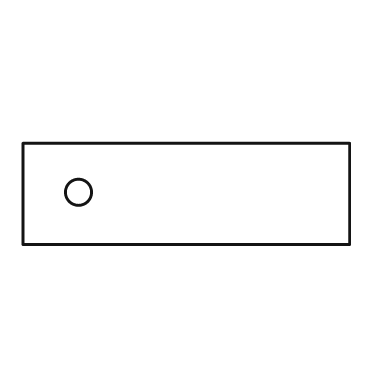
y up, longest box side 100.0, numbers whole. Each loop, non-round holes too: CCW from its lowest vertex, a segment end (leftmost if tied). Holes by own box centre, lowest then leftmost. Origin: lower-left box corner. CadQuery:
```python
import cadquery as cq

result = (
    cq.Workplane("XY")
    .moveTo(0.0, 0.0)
    .lineTo(100.0, 0.0)
    .lineTo(100.0, 31.0)
    .lineTo(0.0, 31.0)
    .close()
    .moveTo(17.0, 16.0)
    .circle(4.0)
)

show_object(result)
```